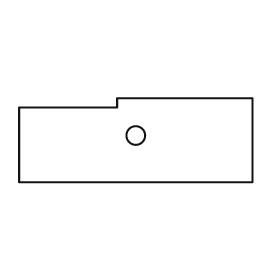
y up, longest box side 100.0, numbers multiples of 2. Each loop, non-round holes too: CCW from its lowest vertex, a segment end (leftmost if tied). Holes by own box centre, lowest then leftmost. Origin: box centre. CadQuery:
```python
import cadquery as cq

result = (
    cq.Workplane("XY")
    .moveTo(-50.0, -18.0)
    .lineTo(50.0, -18.0)
    .lineTo(50.0, 18.0)
    .lineTo(-8.0, 18.0)
    .lineTo(-8.0, 14.0)
    .lineTo(-50.0, 14.0)
    .close()
    .moveTo(0.0, 2.0)
    .circle(4.0)
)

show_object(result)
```